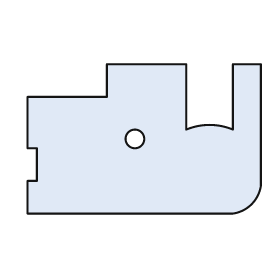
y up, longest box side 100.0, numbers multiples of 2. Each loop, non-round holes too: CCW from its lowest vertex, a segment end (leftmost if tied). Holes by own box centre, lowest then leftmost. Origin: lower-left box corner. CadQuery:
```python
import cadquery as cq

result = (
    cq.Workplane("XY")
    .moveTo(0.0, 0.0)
    .lineTo(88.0, 0.0)
    .threePointArc((96.0, 4.0), (100.0, 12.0))
    .lineTo(100.0, 64.0)
    .lineTo(88.0, 64.0)
    .lineTo(88.0, 36.0)
    .threePointArc((78.0, 38.0), (68.0, 36.0))
    .lineTo(68.0, 64.0)
    .lineTo(34.0, 64.0)
    .lineTo(34.0, 50.0)
    .lineTo(0.0, 50.0)
    .lineTo(0.0, 28.0)
    .lineTo(4.0, 28.0)
    .lineTo(4.0, 14.0)
    .lineTo(0.0, 14.0)
    .close()
    .moveTo(46.0, 32.0)
    .circle(4.0)
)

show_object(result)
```